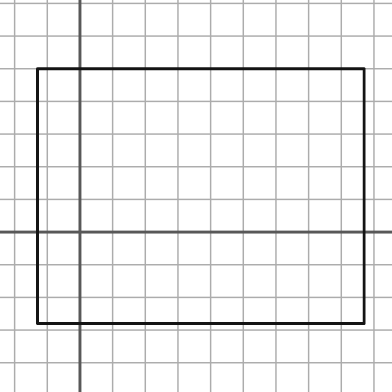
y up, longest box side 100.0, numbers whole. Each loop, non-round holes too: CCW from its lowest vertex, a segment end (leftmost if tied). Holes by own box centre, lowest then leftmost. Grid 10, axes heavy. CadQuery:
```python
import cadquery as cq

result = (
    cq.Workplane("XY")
    .moveTo(-13.0, -28.0)
    .lineTo(87.0, -28.0)
    .lineTo(87.0, 50.0)
    .lineTo(-13.0, 50.0)
    .close()
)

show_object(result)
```